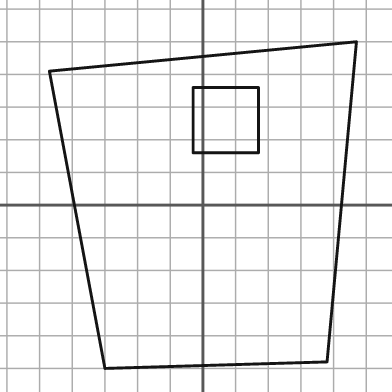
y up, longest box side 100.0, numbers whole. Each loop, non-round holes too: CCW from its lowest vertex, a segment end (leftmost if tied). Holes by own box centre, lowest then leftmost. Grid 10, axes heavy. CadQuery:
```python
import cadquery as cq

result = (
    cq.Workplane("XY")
    .moveTo(-30.0, -50.0)
    .lineTo(38.0, -48.0)
    .lineTo(47.0, 50.0)
    .lineTo(-47.0, 41.0)
    .close()
    .moveTo(-3.0, 16.0)
    .lineTo(17.0, 16.0)
    .lineTo(17.0, 36.0)
    .lineTo(-3.0, 36.0)
    .close()
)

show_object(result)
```